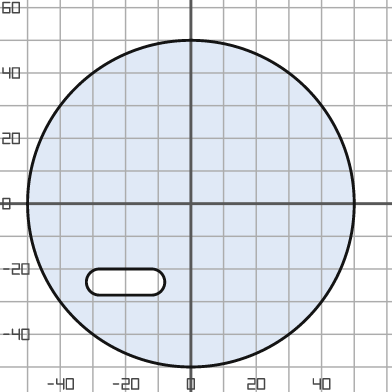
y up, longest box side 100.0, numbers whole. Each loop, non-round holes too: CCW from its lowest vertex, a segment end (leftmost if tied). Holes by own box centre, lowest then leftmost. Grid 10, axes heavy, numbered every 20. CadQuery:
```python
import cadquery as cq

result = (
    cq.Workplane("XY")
    .moveTo(0.0, 0.0)
    .circle(50.0)
    .moveTo(-28.0, -28.0)
    .lineTo(-12.0, -28.0)
    .threePointArc((-8.0, -24.0), (-12.0, -20.0))
    .lineTo(-28.0, -20.0)
    .threePointArc((-32.0, -24.0), (-28.0, -28.0))
    .close()
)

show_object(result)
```